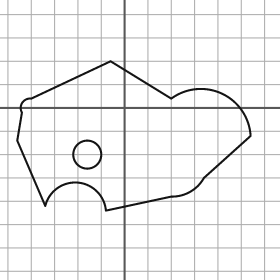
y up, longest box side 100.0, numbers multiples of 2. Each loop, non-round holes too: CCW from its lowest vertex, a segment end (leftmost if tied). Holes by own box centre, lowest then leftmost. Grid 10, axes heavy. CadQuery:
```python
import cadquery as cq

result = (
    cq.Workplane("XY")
    .moveTo(-8.0, -44.0)
    .lineTo(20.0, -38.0)
    .threePointArc((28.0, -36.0), (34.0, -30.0))
    .lineTo(54.0, -12.0)
    .threePointArc((42.0, 6.0), (20.0, 4.0))
    .lineTo(-6.0, 20.0)
    .lineTo(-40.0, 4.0)
    .threePointArc((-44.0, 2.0), (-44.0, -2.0))
    .lineTo(-46.0, -14.0)
    .lineTo(-34.0, -42.0)
    .threePointArc((-20.0, -32.0), (-8.0, -44.0))
    .close()
    .moveTo(-16.0, -20.0)
    .circle(6.0)
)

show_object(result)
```